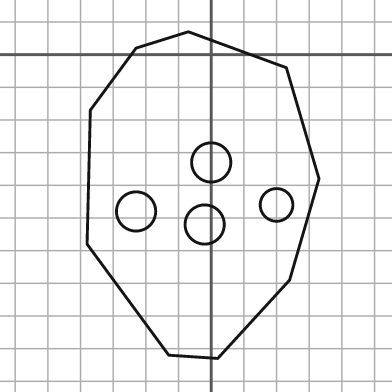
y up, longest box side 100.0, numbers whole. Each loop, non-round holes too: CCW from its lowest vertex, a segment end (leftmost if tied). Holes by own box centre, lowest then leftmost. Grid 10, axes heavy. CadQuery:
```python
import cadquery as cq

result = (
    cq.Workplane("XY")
    .moveTo(2.0, -93.0)
    .lineTo(24.0, -69.0)
    .lineTo(33.0, -38.0)
    .lineTo(23.0, -4.0)
    .lineTo(-7.0, 7.0)
    .lineTo(-23.0, 2.0)
    .lineTo(-37.0, -17.0)
    .lineTo(-38.0, -58.0)
    .lineTo(-13.0, -92.0)
    .close()
    .moveTo(-2.0, -52.0)
    .circle(6.0)
    .moveTo(-23.0, -48.0)
    .circle(6.0)
    .moveTo(20.0, -46.0)
    .circle(5.0)
    .moveTo(0.0, -33.0)
    .circle(6.0)
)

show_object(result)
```